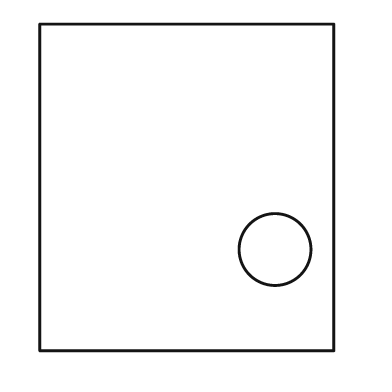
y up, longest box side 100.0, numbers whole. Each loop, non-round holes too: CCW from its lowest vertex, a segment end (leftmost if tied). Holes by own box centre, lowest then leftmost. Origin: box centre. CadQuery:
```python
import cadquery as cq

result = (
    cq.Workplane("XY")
    .moveTo(-45.0, -50.0)
    .lineTo(45.0, -50.0)
    .lineTo(45.0, 50.0)
    .lineTo(-45.0, 50.0)
    .close()
    .moveTo(27.0, -19.0)
    .circle(11.0)
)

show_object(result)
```